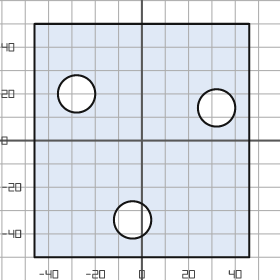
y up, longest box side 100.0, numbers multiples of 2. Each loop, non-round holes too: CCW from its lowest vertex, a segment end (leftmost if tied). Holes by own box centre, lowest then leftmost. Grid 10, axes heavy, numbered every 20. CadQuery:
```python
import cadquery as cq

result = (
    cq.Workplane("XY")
    .moveTo(-46.0, -50.0)
    .lineTo(46.0, -50.0)
    .lineTo(46.0, 50.0)
    .lineTo(-46.0, 50.0)
    .close()
    .moveTo(-4.0, -34.0)
    .circle(8.0)
    .moveTo(32.0, 14.0)
    .circle(8.0)
    .moveTo(-28.0, 20.0)
    .circle(8.0)
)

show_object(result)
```